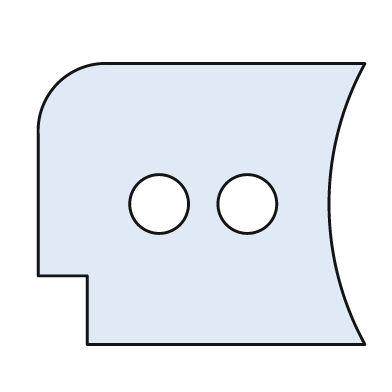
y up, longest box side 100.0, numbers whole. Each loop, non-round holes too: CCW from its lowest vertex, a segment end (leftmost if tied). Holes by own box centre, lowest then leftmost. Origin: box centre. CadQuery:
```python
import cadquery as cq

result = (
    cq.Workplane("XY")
    .moveTo(-35.0, -43.0)
    .lineTo(50.0, -43.0)
    .threePointArc((39.0, 0.0), (50.0, 43.0))
    .lineTo(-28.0, 43.0)
    .threePointArc((-44.0, 37.0), (-50.0, 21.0))
    .lineTo(-50.0, -22.0)
    .lineTo(-35.0, -22.0)
    .close()
    .moveTo(-13.0, 0.0)
    .circle(9.0)
    .moveTo(14.0, 0.0)
    .circle(9.0)
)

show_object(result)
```